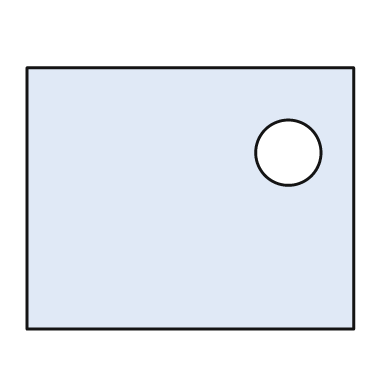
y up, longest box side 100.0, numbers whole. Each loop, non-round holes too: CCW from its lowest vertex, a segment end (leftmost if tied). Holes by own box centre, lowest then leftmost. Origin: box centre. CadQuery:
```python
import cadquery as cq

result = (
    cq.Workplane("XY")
    .moveTo(-50.0, -40.0)
    .lineTo(50.0, -40.0)
    .lineTo(50.0, 40.0)
    .lineTo(-50.0, 40.0)
    .close()
    .moveTo(30.0, 14.0)
    .circle(10.0)
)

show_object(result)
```